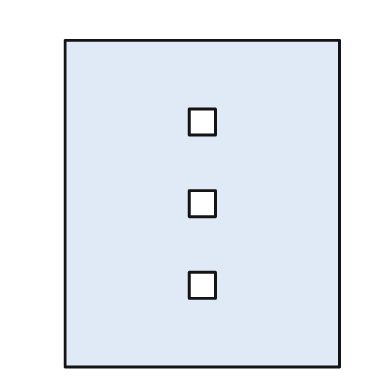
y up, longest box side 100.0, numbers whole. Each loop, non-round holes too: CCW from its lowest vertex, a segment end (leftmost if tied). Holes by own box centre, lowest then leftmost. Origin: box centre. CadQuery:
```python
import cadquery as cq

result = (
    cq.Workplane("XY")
    .moveTo(-42.0, -50.0)
    .lineTo(42.0, -50.0)
    .lineTo(42.0, 50.0)
    .lineTo(-42.0, 50.0)
    .close()
    .moveTo(-4.0, -29.0)
    .lineTo(4.0, -29.0)
    .lineTo(4.0, -21.0)
    .lineTo(-4.0, -21.0)
    .close()
    .moveTo(-4.0, -4.0)
    .lineTo(4.0, -4.0)
    .lineTo(4.0, 4.0)
    .lineTo(-4.0, 4.0)
    .close()
    .moveTo(-4.0, 21.0)
    .lineTo(4.0, 21.0)
    .lineTo(4.0, 29.0)
    .lineTo(-4.0, 29.0)
    .close()
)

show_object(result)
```